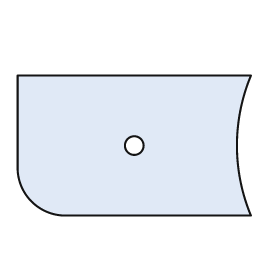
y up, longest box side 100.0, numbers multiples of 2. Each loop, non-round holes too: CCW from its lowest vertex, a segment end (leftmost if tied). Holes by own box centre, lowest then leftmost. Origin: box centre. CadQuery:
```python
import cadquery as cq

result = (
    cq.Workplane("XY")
    .moveTo(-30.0, -30.0)
    .lineTo(50.0, -30.0)
    .threePointArc((44.0, 0.0), (50.0, 30.0))
    .lineTo(-50.0, 30.0)
    .lineTo(-50.0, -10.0)
    .threePointArc((-44.0, -24.0), (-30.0, -30.0))
    .close()
    .moveTo(0.0, 0.0)
    .circle(4.0)
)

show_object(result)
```